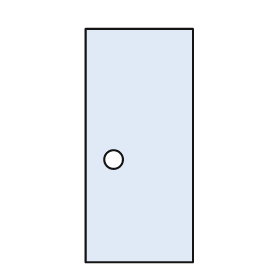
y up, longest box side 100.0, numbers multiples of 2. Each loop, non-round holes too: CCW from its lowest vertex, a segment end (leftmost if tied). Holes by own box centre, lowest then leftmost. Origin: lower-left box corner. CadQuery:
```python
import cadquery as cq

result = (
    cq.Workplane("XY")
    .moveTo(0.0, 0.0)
    .lineTo(46.0, 0.0)
    .lineTo(46.0, 100.0)
    .lineTo(0.0, 100.0)
    .close()
    .moveTo(12.0, 44.0)
    .circle(4.0)
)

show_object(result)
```